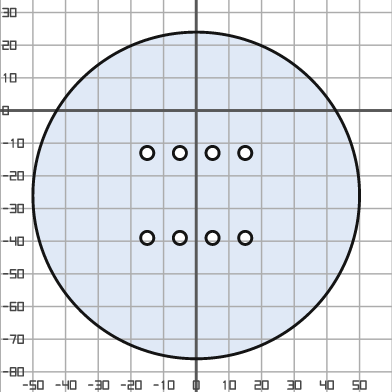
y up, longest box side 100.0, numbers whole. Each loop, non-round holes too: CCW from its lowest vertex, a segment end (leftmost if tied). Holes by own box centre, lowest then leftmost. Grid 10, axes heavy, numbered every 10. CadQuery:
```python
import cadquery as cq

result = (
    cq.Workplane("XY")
    .moveTo(0.0, -26.0)
    .circle(50.0)
    .moveTo(-15.0, -39.0)
    .circle(2.0)
    .moveTo(-5.0, -39.0)
    .circle(2.0)
    .moveTo(5.0, -39.0)
    .circle(2.0)
    .moveTo(15.0, -39.0)
    .circle(2.0)
    .moveTo(-15.0, -13.0)
    .circle(2.0)
    .moveTo(-5.0, -13.0)
    .circle(2.0)
    .moveTo(5.0, -13.0)
    .circle(2.0)
    .moveTo(15.0, -13.0)
    .circle(2.0)
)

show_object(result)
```